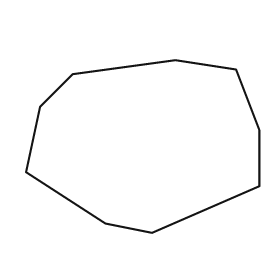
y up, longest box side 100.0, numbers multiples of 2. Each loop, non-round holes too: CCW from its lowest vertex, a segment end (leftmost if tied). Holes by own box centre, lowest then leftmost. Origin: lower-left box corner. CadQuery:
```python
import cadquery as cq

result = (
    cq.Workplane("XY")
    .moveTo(54.0, 0.0)
    .lineTo(100.0, 20.0)
    .lineTo(100.0, 44.0)
    .lineTo(90.0, 70.0)
    .lineTo(64.0, 74.0)
    .lineTo(20.0, 68.0)
    .lineTo(6.0, 54.0)
    .lineTo(0.0, 26.0)
    .lineTo(34.0, 4.0)
    .close()
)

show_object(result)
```